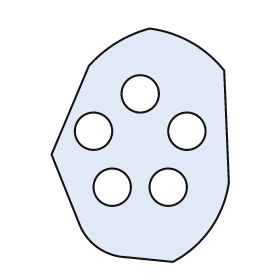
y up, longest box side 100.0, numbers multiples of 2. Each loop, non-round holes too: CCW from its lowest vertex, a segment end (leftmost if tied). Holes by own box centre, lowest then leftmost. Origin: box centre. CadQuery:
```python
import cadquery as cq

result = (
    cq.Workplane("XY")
    .moveTo(14.0, -50.0)
    .threePointArc((30.0, -36.0), (38.0, -16.0))
    .lineTo(36.0, 32.0)
    .threePointArc((22.0, 44.0), (4.0, 50.0))
    .threePointArc((-10.0, 44.0), (-22.0, 34.0))
    .lineTo(-38.0, -4.0)
    .lineTo(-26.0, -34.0)
    .threePointArc((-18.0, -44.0), (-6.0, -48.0))
    .close()
    .moveTo(-12.0, -18.0)
    .circle(8.0)
    .moveTo(12.0, -18.0)
    .circle(8.0)
    .moveTo(-20.0, 6.0)
    .circle(8.0)
    .moveTo(20.0, 6.0)
    .circle(8.0)
    .moveTo(0.0, 22.0)
    .circle(8.0)
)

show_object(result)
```